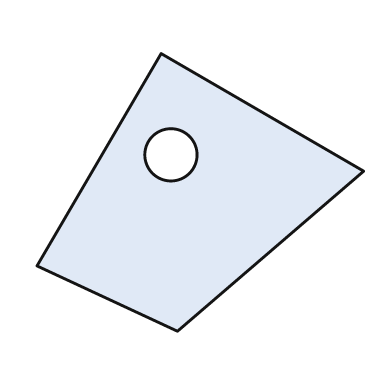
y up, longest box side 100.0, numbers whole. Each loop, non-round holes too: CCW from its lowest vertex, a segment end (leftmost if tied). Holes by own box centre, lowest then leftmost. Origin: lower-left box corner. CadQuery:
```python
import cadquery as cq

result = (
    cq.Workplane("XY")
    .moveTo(43.0, 0.0)
    .lineTo(100.0, 49.0)
    .lineTo(38.0, 85.0)
    .lineTo(0.0, 20.0)
    .close()
    .moveTo(41.0, 54.0)
    .circle(8.0)
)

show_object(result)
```